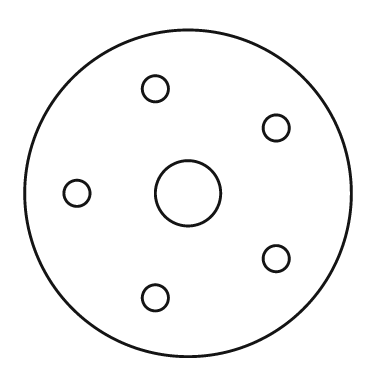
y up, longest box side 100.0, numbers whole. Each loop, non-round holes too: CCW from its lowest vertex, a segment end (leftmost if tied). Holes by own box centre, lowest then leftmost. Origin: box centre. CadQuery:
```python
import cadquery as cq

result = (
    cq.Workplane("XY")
    .moveTo(0.0, 0.0)
    .circle(50.0)
    .moveTo(-10.0, -32.0)
    .circle(4.0)
    .moveTo(27.0, -20.0)
    .circle(4.0)
    .moveTo(-34.0, 0.0)
    .circle(4.0)
    .moveTo(0.0, 0.0)
    .circle(10.0)
    .moveTo(27.0, 20.0)
    .circle(4.0)
    .moveTo(-10.0, 32.0)
    .circle(4.0)
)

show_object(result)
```